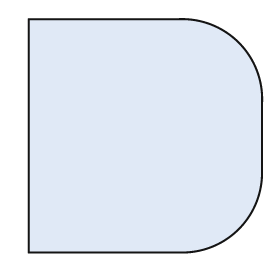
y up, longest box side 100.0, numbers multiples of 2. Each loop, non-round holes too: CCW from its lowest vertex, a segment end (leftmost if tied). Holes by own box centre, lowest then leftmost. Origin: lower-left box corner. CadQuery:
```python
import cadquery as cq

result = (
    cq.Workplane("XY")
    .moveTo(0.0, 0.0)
    .lineTo(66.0, 0.0)
    .threePointArc((90.0, 10.0), (100.0, 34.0))
    .lineTo(100.0, 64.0)
    .threePointArc((90.0, 90.0), (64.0, 100.0))
    .lineTo(0.0, 100.0)
    .close()
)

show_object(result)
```